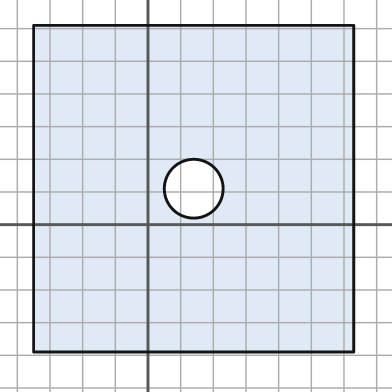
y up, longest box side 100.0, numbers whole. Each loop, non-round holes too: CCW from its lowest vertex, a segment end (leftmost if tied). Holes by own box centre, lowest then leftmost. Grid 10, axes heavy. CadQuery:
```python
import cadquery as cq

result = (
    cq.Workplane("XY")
    .moveTo(-35.0, -39.0)
    .lineTo(63.0, -39.0)
    .lineTo(63.0, 61.0)
    .lineTo(-35.0, 61.0)
    .close()
    .moveTo(14.0, 11.0)
    .circle(9.0)
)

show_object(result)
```